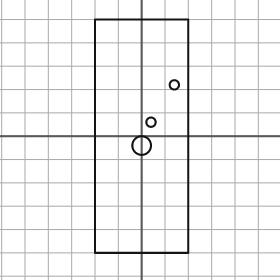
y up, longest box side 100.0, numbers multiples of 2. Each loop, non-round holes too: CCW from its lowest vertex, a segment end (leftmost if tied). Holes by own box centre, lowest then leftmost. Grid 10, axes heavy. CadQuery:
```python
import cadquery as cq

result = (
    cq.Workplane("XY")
    .moveTo(-20.0, -50.0)
    .lineTo(20.0, -50.0)
    .lineTo(20.0, 50.0)
    .lineTo(-20.0, 50.0)
    .close()
    .moveTo(0.0, -4.0)
    .circle(4.0)
    .moveTo(4.0, 6.0)
    .circle(2.0)
    .moveTo(14.0, 22.0)
    .circle(2.0)
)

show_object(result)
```